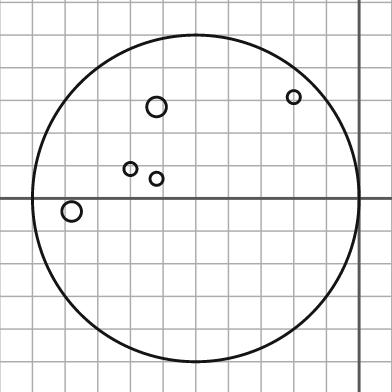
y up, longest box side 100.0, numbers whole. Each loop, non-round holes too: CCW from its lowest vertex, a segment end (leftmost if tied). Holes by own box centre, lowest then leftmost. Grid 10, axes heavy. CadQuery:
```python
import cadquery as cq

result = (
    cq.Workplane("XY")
    .moveTo(-50.0, 0.0)
    .circle(50.0)
    .moveTo(-88.0, -4.0)
    .circle(3.0)
    .moveTo(-62.0, 6.0)
    .circle(2.0)
    .moveTo(-70.0, 9.0)
    .circle(2.0)
    .moveTo(-62.0, 28.0)
    .circle(3.0)
    .moveTo(-20.0, 31.0)
    .circle(2.0)
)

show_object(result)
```